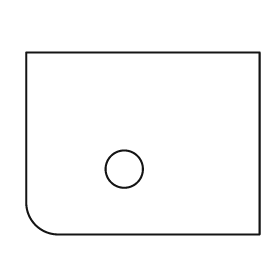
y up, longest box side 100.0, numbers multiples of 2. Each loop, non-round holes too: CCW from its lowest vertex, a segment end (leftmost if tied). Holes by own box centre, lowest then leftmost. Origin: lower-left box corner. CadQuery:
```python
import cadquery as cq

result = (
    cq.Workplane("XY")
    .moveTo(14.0, 0.0)
    .lineTo(100.0, 0.0)
    .lineTo(100.0, 78.0)
    .lineTo(0.0, 78.0)
    .lineTo(0.0, 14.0)
    .threePointArc((4.0, 4.0), (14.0, 0.0))
    .close()
    .moveTo(42.0, 28.0)
    .circle(8.0)
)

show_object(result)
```